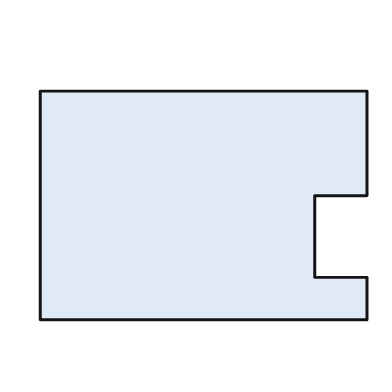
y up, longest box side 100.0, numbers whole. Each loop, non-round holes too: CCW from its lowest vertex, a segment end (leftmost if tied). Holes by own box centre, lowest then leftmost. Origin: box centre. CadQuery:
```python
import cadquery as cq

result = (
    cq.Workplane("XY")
    .moveTo(-50.0, -35.0)
    .lineTo(50.0, -35.0)
    .lineTo(50.0, -22.0)
    .lineTo(34.0, -22.0)
    .lineTo(34.0, 3.0)
    .lineTo(50.0, 3.0)
    .lineTo(50.0, 35.0)
    .lineTo(-50.0, 35.0)
    .close()
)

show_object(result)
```